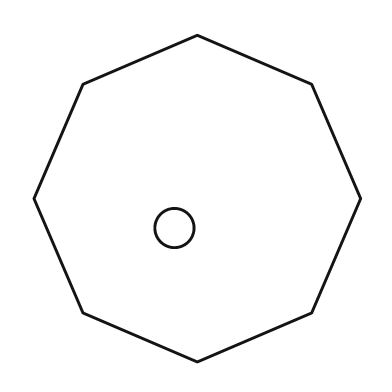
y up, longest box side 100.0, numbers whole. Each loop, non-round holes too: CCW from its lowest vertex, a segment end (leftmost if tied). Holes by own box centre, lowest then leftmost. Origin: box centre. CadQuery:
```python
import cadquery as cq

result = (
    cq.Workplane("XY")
    .moveTo(0.0, -50.0)
    .lineTo(35.0, -35.0)
    .lineTo(50.0, 0.0)
    .lineTo(35.0, 35.0)
    .lineTo(0.0, 50.0)
    .lineTo(-35.0, 35.0)
    .lineTo(-50.0, 0.0)
    .lineTo(-35.0, -35.0)
    .close()
    .moveTo(-7.0, -9.0)
    .circle(6.0)
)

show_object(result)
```